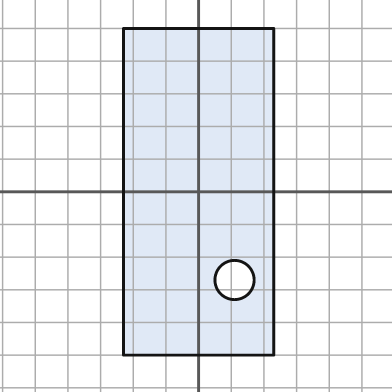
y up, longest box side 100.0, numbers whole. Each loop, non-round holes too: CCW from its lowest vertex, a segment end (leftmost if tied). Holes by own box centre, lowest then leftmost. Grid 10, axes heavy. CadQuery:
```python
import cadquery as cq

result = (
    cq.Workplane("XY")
    .moveTo(-23.0, -50.0)
    .lineTo(23.0, -50.0)
    .lineTo(23.0, 50.0)
    .lineTo(-23.0, 50.0)
    .close()
    .moveTo(11.0, -27.0)
    .circle(6.0)
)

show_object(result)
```